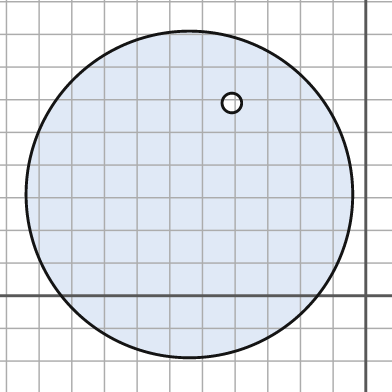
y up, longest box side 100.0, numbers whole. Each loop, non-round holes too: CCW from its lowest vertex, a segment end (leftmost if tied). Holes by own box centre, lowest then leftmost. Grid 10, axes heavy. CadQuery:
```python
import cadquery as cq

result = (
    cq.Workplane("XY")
    .moveTo(-54.0, 31.0)
    .circle(50.0)
    .moveTo(-41.0, 59.0)
    .circle(3.0)
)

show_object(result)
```